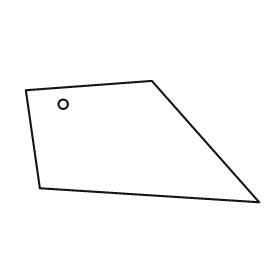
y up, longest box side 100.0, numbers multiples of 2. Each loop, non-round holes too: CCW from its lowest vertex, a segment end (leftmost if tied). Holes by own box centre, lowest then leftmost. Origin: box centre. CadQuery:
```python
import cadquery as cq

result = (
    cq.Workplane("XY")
    .moveTo(50.0, -26.0)
    .lineTo(4.0, 26.0)
    .lineTo(-50.0, 22.0)
    .lineTo(-44.0, -20.0)
    .close()
    .moveTo(-34.0, 16.0)
    .circle(2.0)
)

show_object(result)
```